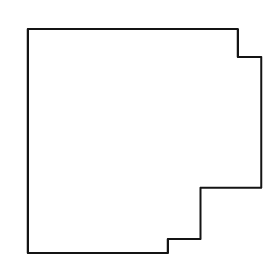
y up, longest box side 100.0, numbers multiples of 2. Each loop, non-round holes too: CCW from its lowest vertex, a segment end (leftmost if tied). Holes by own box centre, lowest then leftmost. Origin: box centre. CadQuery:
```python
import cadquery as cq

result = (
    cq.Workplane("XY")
    .moveTo(-50.0, -48.0)
    .lineTo(10.0, -48.0)
    .lineTo(10.0, -42.0)
    .lineTo(24.0, -42.0)
    .lineTo(24.0, -20.0)
    .lineTo(50.0, -20.0)
    .lineTo(50.0, 36.0)
    .lineTo(40.0, 36.0)
    .lineTo(40.0, 48.0)
    .lineTo(-50.0, 48.0)
    .close()
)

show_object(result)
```